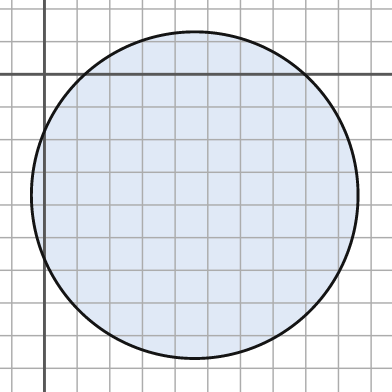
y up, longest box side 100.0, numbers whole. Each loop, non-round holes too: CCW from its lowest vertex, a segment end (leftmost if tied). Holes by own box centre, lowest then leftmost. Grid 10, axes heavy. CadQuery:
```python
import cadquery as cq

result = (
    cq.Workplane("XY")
    .moveTo(46.0, -37.0)
    .circle(50.0)
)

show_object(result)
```